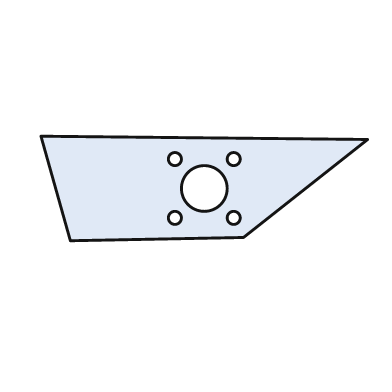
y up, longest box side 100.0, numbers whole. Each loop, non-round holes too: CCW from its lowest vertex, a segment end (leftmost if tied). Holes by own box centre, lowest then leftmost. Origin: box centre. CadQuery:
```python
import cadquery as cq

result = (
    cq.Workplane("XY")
    .moveTo(-41.0, -16.0)
    .lineTo(12.0, -15.0)
    .lineTo(50.0, 15.0)
    .lineTo(-50.0, 16.0)
    .close()
    .moveTo(-9.0, -9.0)
    .circle(2.0)
    .moveTo(9.0, -9.0)
    .circle(2.0)
    .moveTo(0.0, 0.0)
    .circle(7.0)
    .moveTo(-9.0, 9.0)
    .circle(2.0)
    .moveTo(9.0, 9.0)
    .circle(2.0)
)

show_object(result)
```